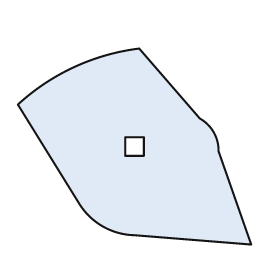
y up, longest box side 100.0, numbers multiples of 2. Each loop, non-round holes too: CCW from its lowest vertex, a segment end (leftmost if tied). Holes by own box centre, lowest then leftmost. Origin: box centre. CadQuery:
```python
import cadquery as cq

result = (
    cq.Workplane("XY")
    .moveTo(50.0, -42.0)
    .lineTo(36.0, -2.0)
    .threePointArc((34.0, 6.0), (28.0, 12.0))
    .lineTo(2.0, 42.0)
    .threePointArc((-26.0, 34.0), (-50.0, 18.0))
    .lineTo(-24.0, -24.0)
    .threePointArc((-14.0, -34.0), (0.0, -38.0))
    .close()
    .moveTo(-4.0, -4.0)
    .lineTo(4.0, -4.0)
    .lineTo(4.0, 4.0)
    .lineTo(-4.0, 4.0)
    .close()
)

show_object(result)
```